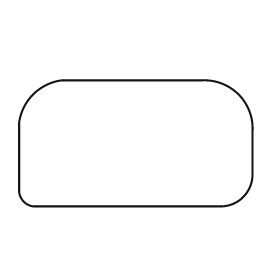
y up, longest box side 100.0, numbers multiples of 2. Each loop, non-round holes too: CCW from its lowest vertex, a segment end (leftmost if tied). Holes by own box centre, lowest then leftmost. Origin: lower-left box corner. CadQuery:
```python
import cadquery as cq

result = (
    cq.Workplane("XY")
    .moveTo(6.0, 0.0)
    .lineTo(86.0, 0.0)
    .threePointArc((96.0, 4.0), (100.0, 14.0))
    .lineTo(100.0, 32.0)
    .threePointArc((94.0, 48.0), (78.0, 54.0))
    .lineTo(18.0, 54.0)
    .threePointArc((6.0, 48.0), (0.0, 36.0))
    .lineTo(0.0, 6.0)
    .threePointArc((2.0, 2.0), (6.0, 0.0))
    .close()
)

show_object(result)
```